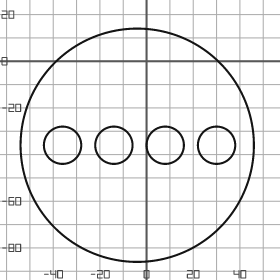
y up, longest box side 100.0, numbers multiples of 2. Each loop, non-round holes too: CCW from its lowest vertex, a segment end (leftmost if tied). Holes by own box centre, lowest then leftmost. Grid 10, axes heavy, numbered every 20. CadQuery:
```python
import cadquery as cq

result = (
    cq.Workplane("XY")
    .moveTo(-4.0, -36.0)
    .circle(50.0)
    .moveTo(-36.0, -36.0)
    .circle(8.0)
    .moveTo(-14.0, -36.0)
    .circle(8.0)
    .moveTo(8.0, -36.0)
    .circle(8.0)
    .moveTo(30.0, -36.0)
    .circle(8.0)
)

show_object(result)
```